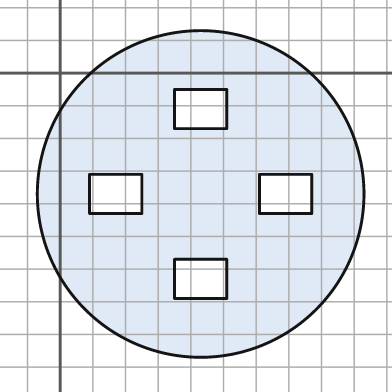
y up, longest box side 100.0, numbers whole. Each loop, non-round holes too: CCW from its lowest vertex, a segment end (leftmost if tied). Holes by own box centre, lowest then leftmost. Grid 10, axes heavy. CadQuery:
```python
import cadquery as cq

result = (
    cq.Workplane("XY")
    .moveTo(43.0, -37.0)
    .circle(50.0)
    .moveTo(35.0, -69.0)
    .lineTo(51.0, -69.0)
    .lineTo(51.0, -57.0)
    .lineTo(35.0, -57.0)
    .close()
    .moveTo(9.0, -43.0)
    .lineTo(25.0, -43.0)
    .lineTo(25.0, -31.0)
    .lineTo(9.0, -31.0)
    .close()
    .moveTo(61.0, -43.0)
    .lineTo(77.0, -43.0)
    .lineTo(77.0, -31.0)
    .lineTo(61.0, -31.0)
    .close()
    .moveTo(35.0, -17.0)
    .lineTo(51.0, -17.0)
    .lineTo(51.0, -5.0)
    .lineTo(35.0, -5.0)
    .close()
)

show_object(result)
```